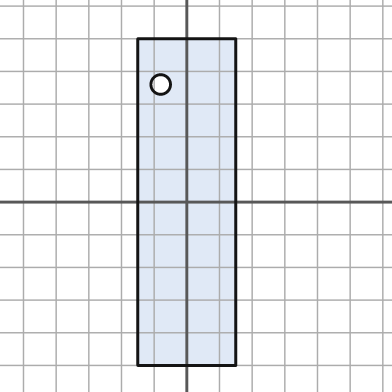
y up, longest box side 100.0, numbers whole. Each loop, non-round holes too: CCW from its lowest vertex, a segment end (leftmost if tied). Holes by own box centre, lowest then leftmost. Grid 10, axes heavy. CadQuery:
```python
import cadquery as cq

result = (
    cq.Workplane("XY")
    .moveTo(-15.0, -50.0)
    .lineTo(15.0, -50.0)
    .lineTo(15.0, 50.0)
    .lineTo(-15.0, 50.0)
    .close()
    .moveTo(-8.0, 36.0)
    .circle(3.0)
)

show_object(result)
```